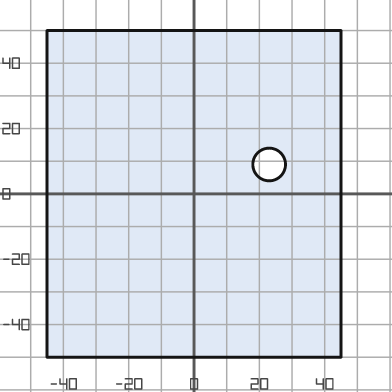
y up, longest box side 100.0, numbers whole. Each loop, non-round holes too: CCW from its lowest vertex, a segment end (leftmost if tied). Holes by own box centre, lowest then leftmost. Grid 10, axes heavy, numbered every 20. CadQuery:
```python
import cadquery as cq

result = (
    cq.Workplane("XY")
    .moveTo(-45.0, -50.0)
    .lineTo(45.0, -50.0)
    .lineTo(45.0, 50.0)
    .lineTo(-45.0, 50.0)
    .close()
    .moveTo(23.0, 9.0)
    .circle(5.0)
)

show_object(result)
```